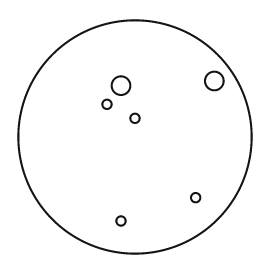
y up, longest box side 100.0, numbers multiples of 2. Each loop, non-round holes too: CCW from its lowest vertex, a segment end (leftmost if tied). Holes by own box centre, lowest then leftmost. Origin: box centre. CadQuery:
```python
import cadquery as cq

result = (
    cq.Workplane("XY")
    .moveTo(0.0, 0.0)
    .circle(50.0)
    .moveTo(-6.0, -36.0)
    .circle(2.0)
    .moveTo(26.0, -26.0)
    .circle(2.0)
    .moveTo(0.0, 8.0)
    .circle(2.0)
    .moveTo(-12.0, 14.0)
    .circle(2.0)
    .moveTo(-6.0, 22.0)
    .circle(4.0)
    .moveTo(34.0, 24.0)
    .circle(4.0)
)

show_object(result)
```